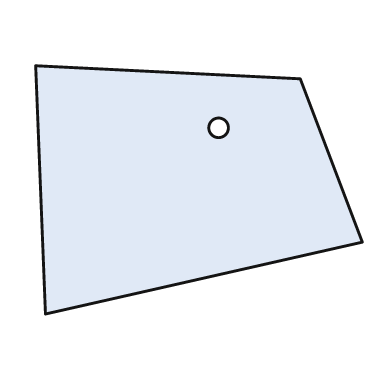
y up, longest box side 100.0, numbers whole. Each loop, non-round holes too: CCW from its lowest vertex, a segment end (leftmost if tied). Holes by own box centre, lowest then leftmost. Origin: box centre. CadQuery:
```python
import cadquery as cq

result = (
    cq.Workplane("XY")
    .moveTo(-47.0, -38.0)
    .lineTo(50.0, -16.0)
    .lineTo(31.0, 34.0)
    .lineTo(-50.0, 38.0)
    .close()
    .moveTo(6.0, 19.0)
    .circle(3.0)
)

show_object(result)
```